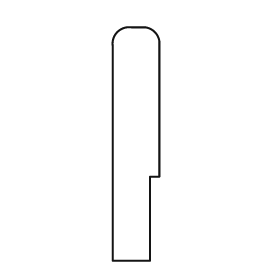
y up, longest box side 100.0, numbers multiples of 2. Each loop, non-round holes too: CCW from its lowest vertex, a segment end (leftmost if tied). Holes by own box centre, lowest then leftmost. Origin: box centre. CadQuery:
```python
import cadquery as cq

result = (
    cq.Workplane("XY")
    .moveTo(-10.0, -50.0)
    .lineTo(6.0, -50.0)
    .lineTo(6.0, -14.0)
    .lineTo(10.0, -14.0)
    .lineTo(10.0, 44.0)
    .threePointArc((8.0, 48.0), (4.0, 50.0))
    .lineTo(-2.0, 50.0)
    .threePointArc((-8.0, 48.0), (-10.0, 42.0))
    .close()
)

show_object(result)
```